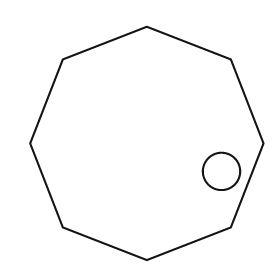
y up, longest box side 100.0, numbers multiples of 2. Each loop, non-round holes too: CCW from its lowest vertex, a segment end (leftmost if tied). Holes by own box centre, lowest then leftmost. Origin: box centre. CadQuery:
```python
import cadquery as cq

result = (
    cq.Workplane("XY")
    .moveTo(0.0, -50.0)
    .lineTo(36.0, -36.0)
    .lineTo(50.0, 0.0)
    .lineTo(36.0, 36.0)
    .lineTo(0.0, 50.0)
    .lineTo(-36.0, 36.0)
    .lineTo(-50.0, 0.0)
    .lineTo(-36.0, -36.0)
    .close()
    .moveTo(32.0, -12.0)
    .circle(8.0)
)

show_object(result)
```